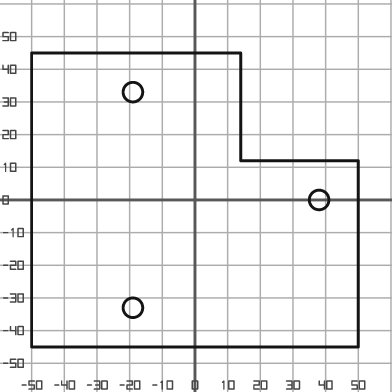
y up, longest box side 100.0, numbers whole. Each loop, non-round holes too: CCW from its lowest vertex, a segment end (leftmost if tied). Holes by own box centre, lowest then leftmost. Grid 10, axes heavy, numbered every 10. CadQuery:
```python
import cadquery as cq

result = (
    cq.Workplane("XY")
    .moveTo(-50.0, -45.0)
    .lineTo(50.0, -45.0)
    .lineTo(50.0, 12.0)
    .lineTo(14.0, 12.0)
    .lineTo(14.0, 45.0)
    .lineTo(-50.0, 45.0)
    .close()
    .moveTo(-19.0, -33.0)
    .circle(3.0)
    .moveTo(38.0, 0.0)
    .circle(3.0)
    .moveTo(-19.0, 33.0)
    .circle(3.0)
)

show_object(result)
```